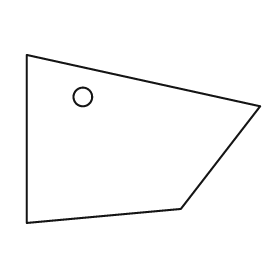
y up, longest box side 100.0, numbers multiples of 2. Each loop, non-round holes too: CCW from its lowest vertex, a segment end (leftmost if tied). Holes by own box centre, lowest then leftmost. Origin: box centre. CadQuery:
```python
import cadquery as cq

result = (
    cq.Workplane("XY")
    .moveTo(-50.0, -36.0)
    .lineTo(16.0, -30.0)
    .lineTo(50.0, 14.0)
    .lineTo(-50.0, 36.0)
    .close()
    .moveTo(-26.0, 18.0)
    .circle(4.0)
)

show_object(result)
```